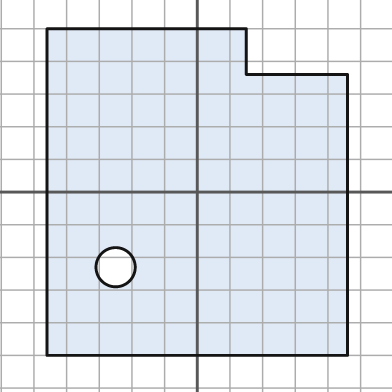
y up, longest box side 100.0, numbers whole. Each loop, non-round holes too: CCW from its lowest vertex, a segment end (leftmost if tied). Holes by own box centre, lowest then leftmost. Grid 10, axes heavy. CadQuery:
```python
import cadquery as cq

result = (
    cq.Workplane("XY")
    .moveTo(-46.0, -50.0)
    .lineTo(46.0, -50.0)
    .lineTo(46.0, 36.0)
    .lineTo(15.0, 36.0)
    .lineTo(15.0, 50.0)
    .lineTo(-46.0, 50.0)
    .close()
    .moveTo(-25.0, -23.0)
    .circle(6.0)
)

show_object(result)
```